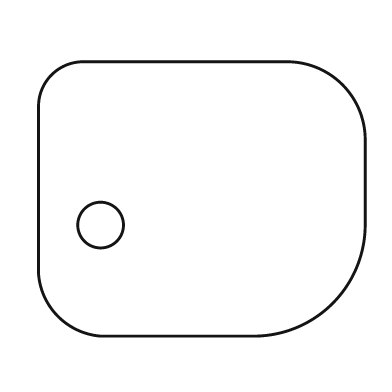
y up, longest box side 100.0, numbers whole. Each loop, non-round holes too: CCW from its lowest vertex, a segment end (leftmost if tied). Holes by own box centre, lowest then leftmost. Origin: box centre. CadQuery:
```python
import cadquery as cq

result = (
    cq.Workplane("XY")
    .moveTo(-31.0, -42.0)
    .lineTo(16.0, -42.0)
    .threePointArc((40.0, -32.0), (50.0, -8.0))
    .lineTo(50.0, 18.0)
    .threePointArc((43.0, 35.0), (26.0, 42.0))
    .lineTo(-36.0, 42.0)
    .threePointArc((-46.0, 38.0), (-50.0, 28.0))
    .lineTo(-50.0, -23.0)
    .threePointArc((-44.0, -36.0), (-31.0, -42.0))
    .close()
    .moveTo(-31.0, -8.0)
    .circle(7.0)
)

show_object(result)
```